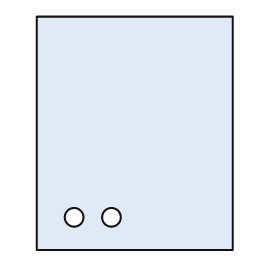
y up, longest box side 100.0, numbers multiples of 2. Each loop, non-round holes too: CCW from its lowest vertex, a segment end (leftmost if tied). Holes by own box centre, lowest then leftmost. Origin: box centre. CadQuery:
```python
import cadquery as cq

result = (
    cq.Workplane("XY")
    .moveTo(-42.0, -50.0)
    .lineTo(42.0, -50.0)
    .lineTo(42.0, 50.0)
    .lineTo(-42.0, 50.0)
    .close()
    .moveTo(-26.0, -36.0)
    .circle(4.0)
    .moveTo(-10.0, -36.0)
    .circle(4.0)
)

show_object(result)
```